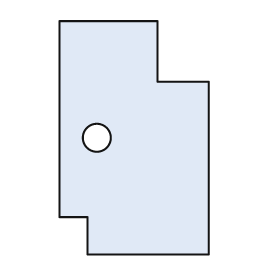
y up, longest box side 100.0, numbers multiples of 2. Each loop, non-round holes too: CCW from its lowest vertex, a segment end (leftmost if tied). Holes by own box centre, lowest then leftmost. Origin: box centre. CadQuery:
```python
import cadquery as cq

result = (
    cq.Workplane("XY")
    .moveTo(-20.0, -50.0)
    .lineTo(32.0, -50.0)
    .lineTo(32.0, 24.0)
    .lineTo(10.0, 24.0)
    .lineTo(10.0, 50.0)
    .lineTo(-32.0, 50.0)
    .lineTo(-32.0, -34.0)
    .lineTo(-20.0, -34.0)
    .close()
    .moveTo(-16.0, 0.0)
    .circle(6.0)
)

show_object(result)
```